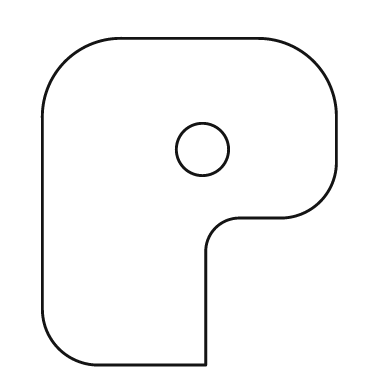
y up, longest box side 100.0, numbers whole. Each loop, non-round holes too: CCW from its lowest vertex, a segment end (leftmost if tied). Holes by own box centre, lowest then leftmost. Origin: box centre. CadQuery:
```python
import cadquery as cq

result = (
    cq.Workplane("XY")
    .moveTo(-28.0, -50.0)
    .lineTo(5.0, -50.0)
    .lineTo(5.0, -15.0)
    .threePointArc((8.0, -8.0), (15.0, -5.0))
    .lineTo(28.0, -5.0)
    .threePointArc((40.0, 0.0), (45.0, 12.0))
    .lineTo(45.0, 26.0)
    .threePointArc((38.0, 43.0), (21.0, 50.0))
    .lineTo(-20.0, 50.0)
    .threePointArc((-38.0, 43.0), (-45.0, 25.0))
    .lineTo(-45.0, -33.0)
    .threePointArc((-40.0, -45.0), (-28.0, -50.0))
    .close()
    .moveTo(4.0, 16.0)
    .circle(8.0)
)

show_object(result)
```